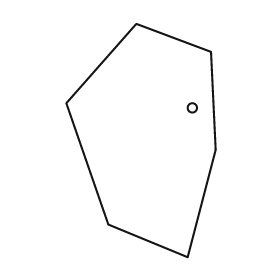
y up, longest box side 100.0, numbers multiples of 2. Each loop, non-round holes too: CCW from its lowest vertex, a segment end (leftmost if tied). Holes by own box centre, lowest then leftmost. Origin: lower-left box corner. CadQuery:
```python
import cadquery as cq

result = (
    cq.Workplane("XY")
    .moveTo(52.0, 0.0)
    .lineTo(64.0, 46.0)
    .lineTo(62.0, 88.0)
    .lineTo(30.0, 100.0)
    .lineTo(0.0, 66.0)
    .lineTo(18.0, 14.0)
    .close()
    .moveTo(54.0, 64.0)
    .circle(2.0)
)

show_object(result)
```